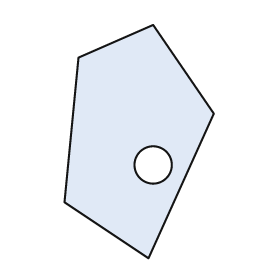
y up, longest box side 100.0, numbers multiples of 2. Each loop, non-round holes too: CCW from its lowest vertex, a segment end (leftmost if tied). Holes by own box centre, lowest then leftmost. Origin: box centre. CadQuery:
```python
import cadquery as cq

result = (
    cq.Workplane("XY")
    .moveTo(4.0, -50.0)
    .lineTo(32.0, 12.0)
    .lineTo(6.0, 50.0)
    .lineTo(-26.0, 36.0)
    .lineTo(-32.0, -26.0)
    .close()
    .moveTo(6.0, -10.0)
    .circle(8.0)
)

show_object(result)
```